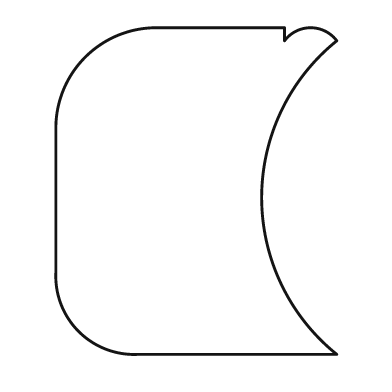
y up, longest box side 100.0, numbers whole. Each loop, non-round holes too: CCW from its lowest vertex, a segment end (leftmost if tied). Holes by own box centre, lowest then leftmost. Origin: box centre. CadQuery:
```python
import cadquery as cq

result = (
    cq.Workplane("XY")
    .moveTo(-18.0, -50.0)
    .lineTo(43.0, -50.0)
    .threePointArc((20.0, -2.0), (43.0, 46.0))
    .threePointArc((35.0, 50.0), (27.0, 46.0))
    .lineTo(27.0, 50.0)
    .lineTo(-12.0, 50.0)
    .threePointArc((-34.0, 41.0), (-43.0, 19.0))
    .lineTo(-43.0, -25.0)
    .threePointArc((-36.0, -43.0), (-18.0, -50.0))
    .close()
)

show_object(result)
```